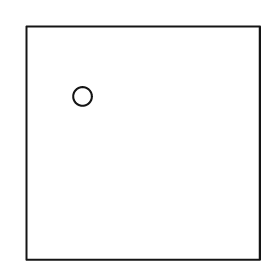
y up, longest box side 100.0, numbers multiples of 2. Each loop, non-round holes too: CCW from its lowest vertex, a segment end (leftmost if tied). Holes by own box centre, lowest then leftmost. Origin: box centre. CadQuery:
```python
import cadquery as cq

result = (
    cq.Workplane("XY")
    .moveTo(-50.0, -50.0)
    .lineTo(50.0, -50.0)
    .lineTo(50.0, 50.0)
    .lineTo(-50.0, 50.0)
    .close()
    .moveTo(-26.0, 20.0)
    .circle(4.0)
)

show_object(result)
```